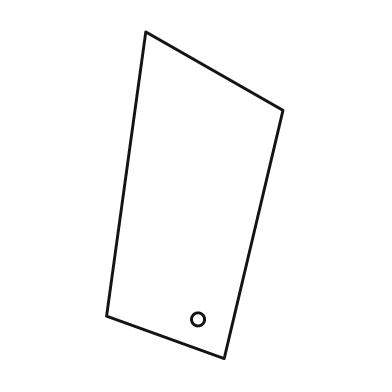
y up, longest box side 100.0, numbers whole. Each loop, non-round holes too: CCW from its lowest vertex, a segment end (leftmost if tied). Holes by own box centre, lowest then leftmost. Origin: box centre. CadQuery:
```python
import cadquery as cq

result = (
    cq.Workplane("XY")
    .moveTo(9.0, -50.0)
    .lineTo(27.0, 26.0)
    .lineTo(-15.0, 50.0)
    .lineTo(-27.0, -37.0)
    .close()
    .moveTo(1.0, -38.0)
    .circle(2.0)
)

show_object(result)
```